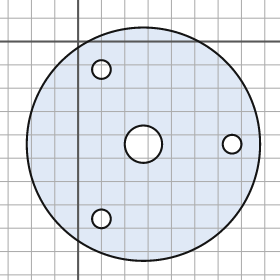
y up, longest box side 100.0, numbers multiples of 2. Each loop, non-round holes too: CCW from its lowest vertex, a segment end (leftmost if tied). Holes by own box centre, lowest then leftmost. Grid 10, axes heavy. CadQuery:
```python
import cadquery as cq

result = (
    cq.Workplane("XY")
    .moveTo(28.0, -44.0)
    .circle(50.0)
    .moveTo(10.0, -76.0)
    .circle(4.0)
    .moveTo(28.0, -44.0)
    .circle(8.0)
    .moveTo(66.0, -44.0)
    .circle(4.0)
    .moveTo(10.0, -12.0)
    .circle(4.0)
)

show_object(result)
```